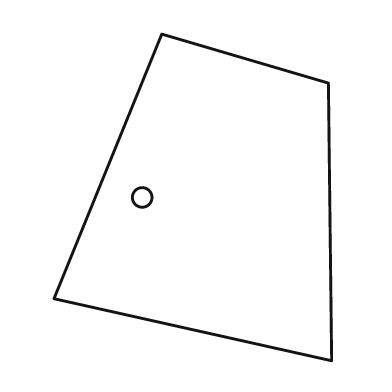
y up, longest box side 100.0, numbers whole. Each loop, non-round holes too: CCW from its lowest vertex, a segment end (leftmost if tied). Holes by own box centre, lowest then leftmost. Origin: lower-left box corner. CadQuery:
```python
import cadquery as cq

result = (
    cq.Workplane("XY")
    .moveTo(85.0, 0.0)
    .lineTo(84.0, 85.0)
    .lineTo(33.0, 100.0)
    .lineTo(0.0, 19.0)
    .close()
    .moveTo(27.0, 50.0)
    .circle(3.0)
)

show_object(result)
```